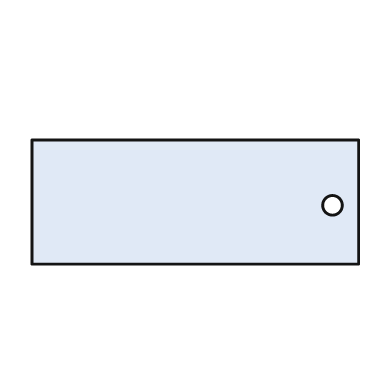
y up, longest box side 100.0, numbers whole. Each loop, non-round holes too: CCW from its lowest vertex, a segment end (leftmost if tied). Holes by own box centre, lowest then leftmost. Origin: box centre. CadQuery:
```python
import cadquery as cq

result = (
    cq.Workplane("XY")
    .moveTo(-50.0, -19.0)
    .lineTo(50.0, -19.0)
    .lineTo(50.0, 19.0)
    .lineTo(-50.0, 19.0)
    .close()
    .moveTo(42.0, -1.0)
    .circle(3.0)
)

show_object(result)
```